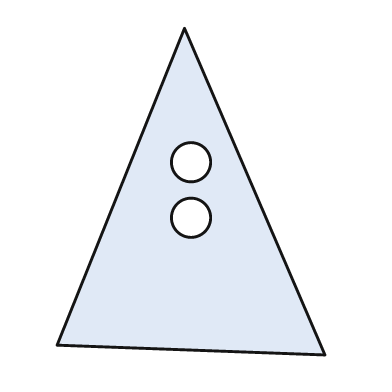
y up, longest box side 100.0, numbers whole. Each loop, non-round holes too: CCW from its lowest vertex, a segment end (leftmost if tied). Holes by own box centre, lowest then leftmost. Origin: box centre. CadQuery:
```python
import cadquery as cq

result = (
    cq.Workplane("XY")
    .moveTo(41.0, -50.0)
    .lineTo(-2.0, 50.0)
    .lineTo(-41.0, -47.0)
    .close()
    .moveTo(0.0, -8.0)
    .circle(6.0)
    .moveTo(0.0, 9.0)
    .circle(6.0)
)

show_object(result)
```